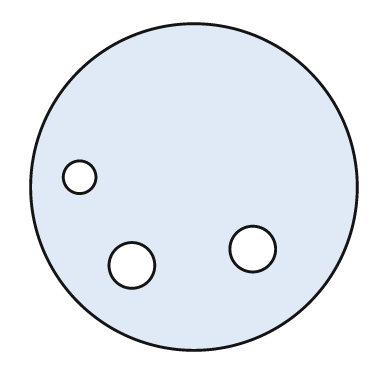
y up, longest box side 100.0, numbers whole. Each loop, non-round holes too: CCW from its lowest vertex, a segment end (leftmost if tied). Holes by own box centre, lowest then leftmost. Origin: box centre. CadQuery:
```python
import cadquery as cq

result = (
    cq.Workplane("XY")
    .moveTo(0.0, 0.0)
    .circle(50.0)
    .moveTo(-19.0, -24.0)
    .circle(7.0)
    .moveTo(18.0, -19.0)
    .circle(7.0)
    .moveTo(-35.0, 3.0)
    .circle(5.0)
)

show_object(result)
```